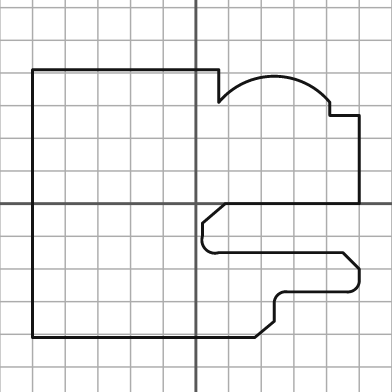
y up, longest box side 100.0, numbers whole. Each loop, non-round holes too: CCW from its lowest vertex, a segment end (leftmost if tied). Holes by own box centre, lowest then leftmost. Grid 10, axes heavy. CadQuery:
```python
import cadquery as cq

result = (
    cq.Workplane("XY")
    .moveTo(-50.0, -41.0)
    .lineTo(18.0, -41.0)
    .lineTo(24.0, -36.0)
    .lineTo(24.0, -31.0)
    .threePointArc((25.0, -28.0), (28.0, -27.0))
    .lineTo(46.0, -27.0)
    .threePointArc((49.0, -26.0), (50.0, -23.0))
    .lineTo(50.0, -20.0)
    .lineTo(45.0, -15.0)
    .lineTo(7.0, -15.0)
    .threePointArc((3.0, -14.0), (2.0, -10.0))
    .lineTo(2.0, -6.0)
    .lineTo(9.0, 0.0)
    .lineTo(50.0, 0.0)
    .lineTo(50.0, 27.0)
    .lineTo(41.0, 27.0)
    .lineTo(41.0, 31.0)
    .threePointArc((24.0, 39.0), (7.0, 31.0))
    .lineTo(7.0, 41.0)
    .lineTo(-50.0, 41.0)
    .close()
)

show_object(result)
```